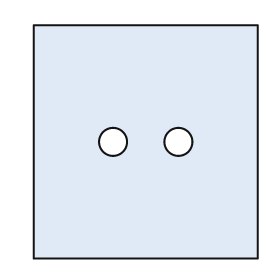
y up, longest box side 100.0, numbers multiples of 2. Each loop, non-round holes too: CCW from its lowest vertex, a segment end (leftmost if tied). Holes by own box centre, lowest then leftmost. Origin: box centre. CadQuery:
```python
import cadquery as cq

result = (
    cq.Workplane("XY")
    .moveTo(-48.0, -50.0)
    .lineTo(48.0, -50.0)
    .lineTo(48.0, 50.0)
    .lineTo(-48.0, 50.0)
    .close()
    .moveTo(-14.0, 0.0)
    .circle(6.0)
    .moveTo(14.0, 0.0)
    .circle(6.0)
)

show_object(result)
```